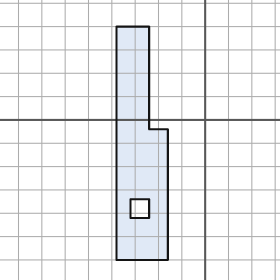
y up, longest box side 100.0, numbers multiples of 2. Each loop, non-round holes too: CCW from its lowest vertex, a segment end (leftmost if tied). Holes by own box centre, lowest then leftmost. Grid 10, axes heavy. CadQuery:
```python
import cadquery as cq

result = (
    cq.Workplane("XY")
    .moveTo(-38.0, -60.0)
    .lineTo(-16.0, -60.0)
    .lineTo(-16.0, -4.0)
    .lineTo(-24.0, -4.0)
    .lineTo(-24.0, 40.0)
    .lineTo(-38.0, 40.0)
    .close()
    .moveTo(-32.0, -42.0)
    .lineTo(-24.0, -42.0)
    .lineTo(-24.0, -34.0)
    .lineTo(-32.0, -34.0)
    .close()
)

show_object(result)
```